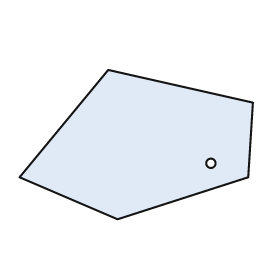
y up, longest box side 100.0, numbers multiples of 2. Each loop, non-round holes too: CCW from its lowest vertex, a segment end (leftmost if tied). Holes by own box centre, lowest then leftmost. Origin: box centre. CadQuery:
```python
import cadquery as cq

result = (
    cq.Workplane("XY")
    .moveTo(-8.0, -32.0)
    .lineTo(48.0, -14.0)
    .lineTo(50.0, 18.0)
    .lineTo(-12.0, 32.0)
    .lineTo(-50.0, -14.0)
    .close()
    .moveTo(32.0, -8.0)
    .circle(2.0)
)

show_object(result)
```